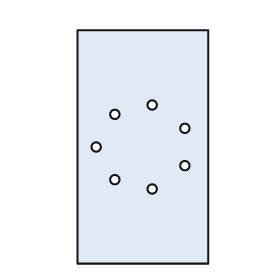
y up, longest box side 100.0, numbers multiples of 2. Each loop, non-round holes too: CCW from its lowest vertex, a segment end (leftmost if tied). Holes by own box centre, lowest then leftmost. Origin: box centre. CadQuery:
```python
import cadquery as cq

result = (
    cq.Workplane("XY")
    .moveTo(-28.0, -50.0)
    .lineTo(28.0, -50.0)
    .lineTo(28.0, 50.0)
    .lineTo(-28.0, 50.0)
    .close()
    .moveTo(4.0, -18.0)
    .circle(2.0)
    .moveTo(-12.0, -14.0)
    .circle(2.0)
    .moveTo(18.0, -8.0)
    .circle(2.0)
    .moveTo(-20.0, 0.0)
    .circle(2.0)
    .moveTo(18.0, 8.0)
    .circle(2.0)
    .moveTo(-12.0, 14.0)
    .circle(2.0)
    .moveTo(4.0, 18.0)
    .circle(2.0)
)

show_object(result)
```